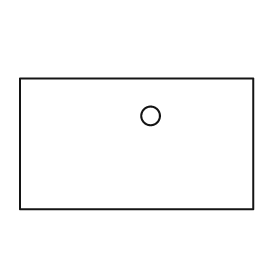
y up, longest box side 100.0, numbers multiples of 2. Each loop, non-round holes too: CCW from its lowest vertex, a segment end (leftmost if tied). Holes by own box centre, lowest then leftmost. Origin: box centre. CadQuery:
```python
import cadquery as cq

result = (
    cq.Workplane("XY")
    .moveTo(-50.0, -28.0)
    .lineTo(50.0, -28.0)
    .lineTo(50.0, 28.0)
    .lineTo(-50.0, 28.0)
    .close()
    .moveTo(6.0, 12.0)
    .circle(4.0)
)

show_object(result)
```